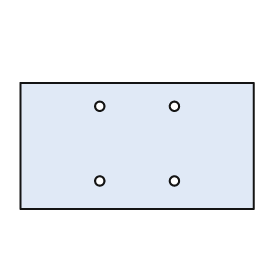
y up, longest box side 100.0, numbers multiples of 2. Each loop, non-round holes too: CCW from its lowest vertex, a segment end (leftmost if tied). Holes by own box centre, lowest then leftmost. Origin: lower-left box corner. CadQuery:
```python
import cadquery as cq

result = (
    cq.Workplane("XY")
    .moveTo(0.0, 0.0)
    .lineTo(100.0, 0.0)
    .lineTo(100.0, 54.0)
    .lineTo(0.0, 54.0)
    .close()
    .moveTo(34.0, 12.0)
    .circle(2.0)
    .moveTo(66.0, 12.0)
    .circle(2.0)
    .moveTo(34.0, 44.0)
    .circle(2.0)
    .moveTo(66.0, 44.0)
    .circle(2.0)
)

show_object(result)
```